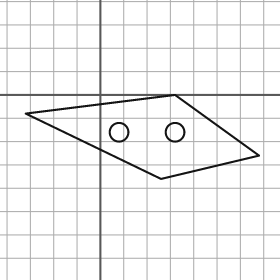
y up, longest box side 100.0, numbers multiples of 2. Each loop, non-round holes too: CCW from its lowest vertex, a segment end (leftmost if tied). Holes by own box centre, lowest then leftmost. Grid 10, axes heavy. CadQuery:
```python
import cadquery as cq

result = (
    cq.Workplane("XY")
    .moveTo(26.0, -36.0)
    .lineTo(68.0, -26.0)
    .lineTo(32.0, 0.0)
    .lineTo(-32.0, -8.0)
    .close()
    .moveTo(8.0, -16.0)
    .circle(4.0)
    .moveTo(32.0, -16.0)
    .circle(4.0)
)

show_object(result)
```